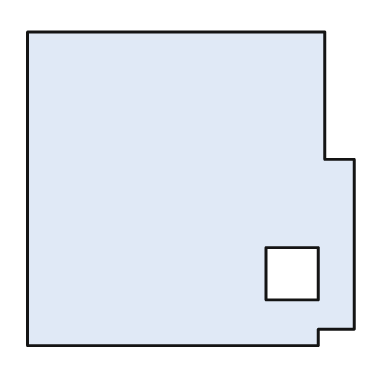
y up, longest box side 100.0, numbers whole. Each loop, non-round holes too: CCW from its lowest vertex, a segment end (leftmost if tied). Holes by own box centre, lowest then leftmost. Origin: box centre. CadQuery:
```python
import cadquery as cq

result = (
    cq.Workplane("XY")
    .moveTo(-50.0, -48.0)
    .lineTo(39.0, -48.0)
    .lineTo(39.0, -43.0)
    .lineTo(50.0, -43.0)
    .lineTo(50.0, 9.0)
    .lineTo(41.0, 9.0)
    .lineTo(41.0, 48.0)
    .lineTo(-50.0, 48.0)
    .close()
    .moveTo(23.0, -34.0)
    .lineTo(39.0, -34.0)
    .lineTo(39.0, -18.0)
    .lineTo(23.0, -18.0)
    .close()
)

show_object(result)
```